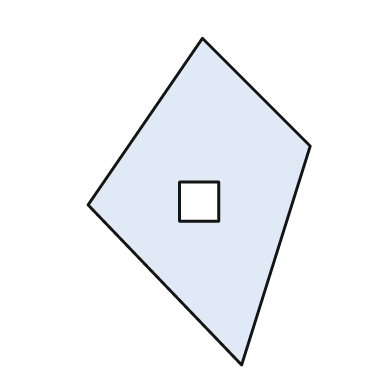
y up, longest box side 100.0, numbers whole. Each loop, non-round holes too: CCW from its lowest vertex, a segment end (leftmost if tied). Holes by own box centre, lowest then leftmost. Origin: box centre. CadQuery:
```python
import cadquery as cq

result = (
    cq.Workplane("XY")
    .moveTo(13.0, -50.0)
    .lineTo(34.0, 17.0)
    .lineTo(1.0, 50.0)
    .lineTo(-34.0, -1.0)
    .close()
    .moveTo(-6.0, -6.0)
    .lineTo(6.0, -6.0)
    .lineTo(6.0, 6.0)
    .lineTo(-6.0, 6.0)
    .close()
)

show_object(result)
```